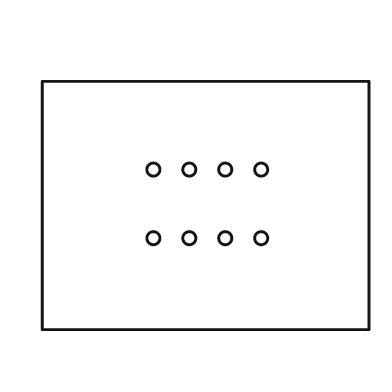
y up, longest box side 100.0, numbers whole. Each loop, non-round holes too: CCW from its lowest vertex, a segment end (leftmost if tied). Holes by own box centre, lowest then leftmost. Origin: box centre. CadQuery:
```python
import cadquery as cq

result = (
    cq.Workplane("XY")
    .moveTo(-50.0, -38.0)
    .lineTo(50.0, -38.0)
    .lineTo(50.0, 38.0)
    .lineTo(-50.0, 38.0)
    .close()
    .moveTo(-16.0, -10.0)
    .circle(2.0)
    .moveTo(-5.0, -10.0)
    .circle(2.0)
    .moveTo(6.0, -10.0)
    .circle(2.0)
    .moveTo(17.0, -10.0)
    .circle(2.0)
    .moveTo(-16.0, 11.0)
    .circle(2.0)
    .moveTo(-5.0, 11.0)
    .circle(2.0)
    .moveTo(6.0, 11.0)
    .circle(2.0)
    .moveTo(17.0, 11.0)
    .circle(2.0)
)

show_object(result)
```